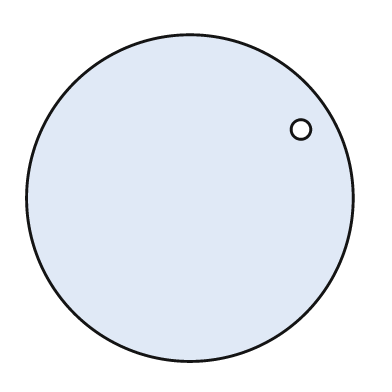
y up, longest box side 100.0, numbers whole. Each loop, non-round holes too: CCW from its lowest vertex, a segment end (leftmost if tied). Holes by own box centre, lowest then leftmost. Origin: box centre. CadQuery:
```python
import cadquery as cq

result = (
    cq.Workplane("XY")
    .moveTo(0.0, 0.0)
    .circle(50.0)
    .moveTo(34.0, 21.0)
    .circle(3.0)
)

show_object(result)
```